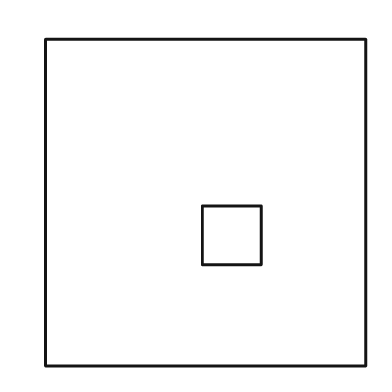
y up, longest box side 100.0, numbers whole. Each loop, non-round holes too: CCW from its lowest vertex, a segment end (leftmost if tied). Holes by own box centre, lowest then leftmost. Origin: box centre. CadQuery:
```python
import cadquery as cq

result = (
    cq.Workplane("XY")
    .moveTo(-49.0, -50.0)
    .lineTo(49.0, -50.0)
    .lineTo(49.0, 50.0)
    .lineTo(-49.0, 50.0)
    .close()
    .moveTo(-1.0, -19.0)
    .lineTo(17.0, -19.0)
    .lineTo(17.0, -1.0)
    .lineTo(-1.0, -1.0)
    .close()
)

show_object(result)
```